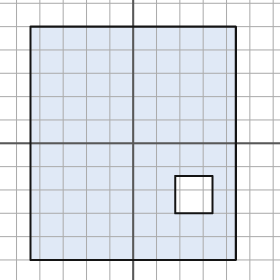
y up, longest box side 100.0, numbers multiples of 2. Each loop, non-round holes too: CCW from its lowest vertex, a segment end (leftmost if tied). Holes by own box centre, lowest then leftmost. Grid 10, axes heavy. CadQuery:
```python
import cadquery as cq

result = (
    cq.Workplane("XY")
    .moveTo(-44.0, -50.0)
    .lineTo(44.0, -50.0)
    .lineTo(44.0, 50.0)
    .lineTo(-44.0, 50.0)
    .close()
    .moveTo(18.0, -30.0)
    .lineTo(34.0, -30.0)
    .lineTo(34.0, -14.0)
    .lineTo(18.0, -14.0)
    .close()
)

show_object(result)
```